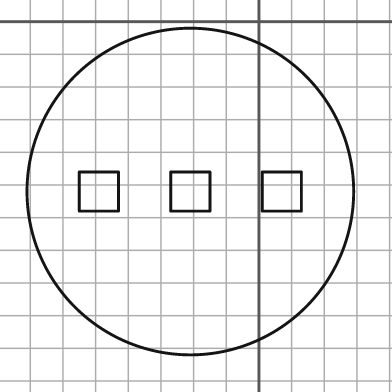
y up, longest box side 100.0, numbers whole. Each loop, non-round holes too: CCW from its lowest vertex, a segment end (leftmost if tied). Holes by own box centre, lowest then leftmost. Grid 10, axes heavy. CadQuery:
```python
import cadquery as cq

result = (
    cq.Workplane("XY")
    .moveTo(-21.0, -52.0)
    .circle(50.0)
    .moveTo(-55.0, -58.0)
    .lineTo(-43.0, -58.0)
    .lineTo(-43.0, -46.0)
    .lineTo(-55.0, -46.0)
    .close()
    .moveTo(-27.0, -58.0)
    .lineTo(-15.0, -58.0)
    .lineTo(-15.0, -46.0)
    .lineTo(-27.0, -46.0)
    .close()
    .moveTo(1.0, -58.0)
    .lineTo(13.0, -58.0)
    .lineTo(13.0, -46.0)
    .lineTo(1.0, -46.0)
    .close()
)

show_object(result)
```